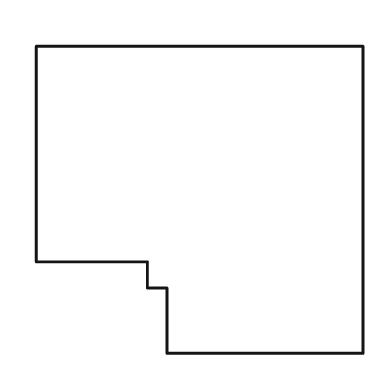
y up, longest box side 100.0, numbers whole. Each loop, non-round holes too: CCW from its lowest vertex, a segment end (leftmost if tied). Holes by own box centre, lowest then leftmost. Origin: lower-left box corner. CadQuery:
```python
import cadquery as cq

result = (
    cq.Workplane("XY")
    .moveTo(40.0, 0.0)
    .lineTo(100.0, 0.0)
    .lineTo(100.0, 94.0)
    .lineTo(0.0, 94.0)
    .lineTo(0.0, 28.0)
    .lineTo(34.0, 28.0)
    .lineTo(34.0, 20.0)
    .lineTo(40.0, 20.0)
    .close()
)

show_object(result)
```